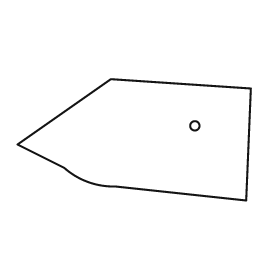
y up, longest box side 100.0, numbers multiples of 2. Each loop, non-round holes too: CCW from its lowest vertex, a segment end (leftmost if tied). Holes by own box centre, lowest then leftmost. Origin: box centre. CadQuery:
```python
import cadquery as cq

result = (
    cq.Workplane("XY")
    .moveTo(48.0, -26.0)
    .lineTo(50.0, 22.0)
    .lineTo(-10.0, 26.0)
    .lineTo(-50.0, -2.0)
    .lineTo(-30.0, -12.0)
    .threePointArc((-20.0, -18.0), (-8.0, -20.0))
    .close()
    .moveTo(26.0, 6.0)
    .circle(2.0)
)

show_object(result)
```